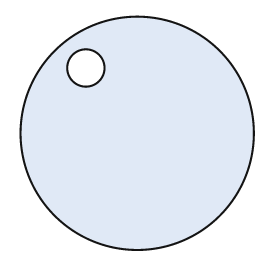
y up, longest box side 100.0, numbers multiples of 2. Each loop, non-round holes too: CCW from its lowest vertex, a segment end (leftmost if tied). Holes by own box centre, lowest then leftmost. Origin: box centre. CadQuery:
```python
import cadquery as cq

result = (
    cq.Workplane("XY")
    .moveTo(0.0, 0.0)
    .circle(50.0)
    .moveTo(-22.0, 28.0)
    .circle(8.0)
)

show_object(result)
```